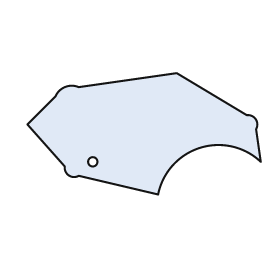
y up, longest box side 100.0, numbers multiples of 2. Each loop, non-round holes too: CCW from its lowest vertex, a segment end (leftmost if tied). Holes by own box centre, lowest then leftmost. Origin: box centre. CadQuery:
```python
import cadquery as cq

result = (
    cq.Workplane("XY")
    .moveTo(6.0, -26.0)
    .threePointArc((24.0, -6.0), (50.0, -12.0))
    .lineTo(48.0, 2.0)
    .threePointArc((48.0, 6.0), (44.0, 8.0))
    .lineTo(14.0, 26.0)
    .lineTo(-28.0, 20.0)
    .threePointArc((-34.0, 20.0), (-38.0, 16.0))
    .lineTo(-50.0, 4.0)
    .lineTo(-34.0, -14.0)
    .threePointArc((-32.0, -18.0), (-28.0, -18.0))
    .close()
    .moveTo(-22.0, -12.0)
    .circle(2.0)
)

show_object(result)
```